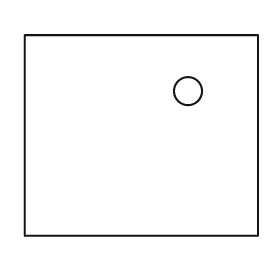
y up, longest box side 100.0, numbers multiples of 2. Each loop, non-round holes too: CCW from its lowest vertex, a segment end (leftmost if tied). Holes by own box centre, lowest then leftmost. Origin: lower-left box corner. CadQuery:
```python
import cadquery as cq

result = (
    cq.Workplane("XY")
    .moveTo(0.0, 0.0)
    .lineTo(100.0, 0.0)
    .lineTo(100.0, 86.0)
    .lineTo(0.0, 86.0)
    .close()
    .moveTo(70.0, 62.0)
    .circle(6.0)
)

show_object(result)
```